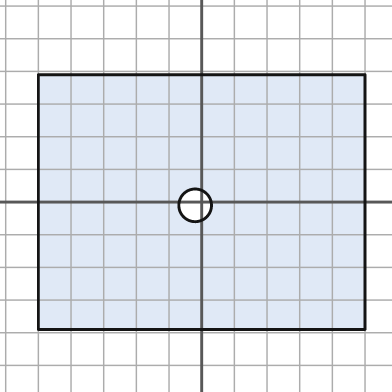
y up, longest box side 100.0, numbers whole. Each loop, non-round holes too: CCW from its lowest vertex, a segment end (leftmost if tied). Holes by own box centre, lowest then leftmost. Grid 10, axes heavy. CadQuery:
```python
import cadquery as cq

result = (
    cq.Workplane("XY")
    .moveTo(-50.0, -39.0)
    .lineTo(50.0, -39.0)
    .lineTo(50.0, 39.0)
    .lineTo(-50.0, 39.0)
    .close()
    .moveTo(-2.0, -1.0)
    .circle(5.0)
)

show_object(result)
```